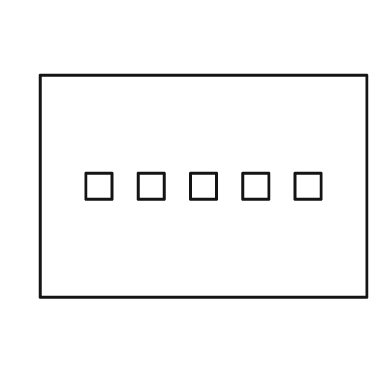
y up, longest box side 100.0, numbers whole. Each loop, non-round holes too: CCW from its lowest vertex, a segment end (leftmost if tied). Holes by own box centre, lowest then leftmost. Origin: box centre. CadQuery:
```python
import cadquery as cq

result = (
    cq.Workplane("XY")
    .moveTo(-50.0, -34.0)
    .lineTo(50.0, -34.0)
    .lineTo(50.0, 34.0)
    .lineTo(-50.0, 34.0)
    .close()
    .moveTo(-36.0, -4.0)
    .lineTo(-28.0, -4.0)
    .lineTo(-28.0, 4.0)
    .lineTo(-36.0, 4.0)
    .close()
    .moveTo(-20.0, -4.0)
    .lineTo(-12.0, -4.0)
    .lineTo(-12.0, 4.0)
    .lineTo(-20.0, 4.0)
    .close()
    .moveTo(-4.0, -4.0)
    .lineTo(4.0, -4.0)
    .lineTo(4.0, 4.0)
    .lineTo(-4.0, 4.0)
    .close()
    .moveTo(12.0, -4.0)
    .lineTo(20.0, -4.0)
    .lineTo(20.0, 4.0)
    .lineTo(12.0, 4.0)
    .close()
    .moveTo(28.0, -4.0)
    .lineTo(36.0, -4.0)
    .lineTo(36.0, 4.0)
    .lineTo(28.0, 4.0)
    .close()
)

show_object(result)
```